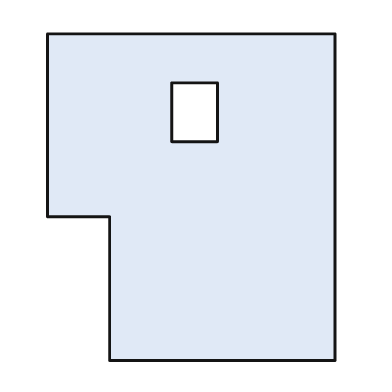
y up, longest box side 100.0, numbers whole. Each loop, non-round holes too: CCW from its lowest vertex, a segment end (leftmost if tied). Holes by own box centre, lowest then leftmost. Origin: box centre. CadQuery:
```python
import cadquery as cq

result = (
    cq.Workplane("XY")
    .moveTo(-25.0, -50.0)
    .lineTo(44.0, -50.0)
    .lineTo(44.0, 50.0)
    .lineTo(-44.0, 50.0)
    .lineTo(-44.0, -6.0)
    .lineTo(-25.0, -6.0)
    .close()
    .moveTo(-6.0, 17.0)
    .lineTo(8.0, 17.0)
    .lineTo(8.0, 35.0)
    .lineTo(-6.0, 35.0)
    .close()
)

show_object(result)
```